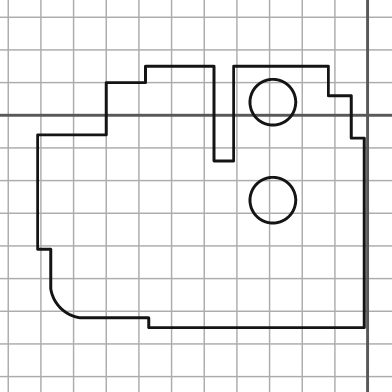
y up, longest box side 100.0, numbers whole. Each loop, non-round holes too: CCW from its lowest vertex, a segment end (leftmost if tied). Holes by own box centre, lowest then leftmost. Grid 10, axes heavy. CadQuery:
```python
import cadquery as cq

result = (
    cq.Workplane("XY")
    .moveTo(-67.0, -65.0)
    .lineTo(-1.0, -65.0)
    .lineTo(-1.0, -7.0)
    .lineTo(-5.0, -7.0)
    .lineTo(-5.0, 6.0)
    .lineTo(-12.0, 6.0)
    .lineTo(-12.0, 15.0)
    .lineTo(-41.0, 15.0)
    .lineTo(-41.0, -14.0)
    .lineTo(-47.0, -14.0)
    .lineTo(-47.0, 15.0)
    .lineTo(-68.0, 15.0)
    .lineTo(-68.0, 10.0)
    .lineTo(-80.0, 10.0)
    .lineTo(-80.0, -6.0)
    .lineTo(-101.0, -6.0)
    .lineTo(-101.0, -41.0)
    .lineTo(-97.0, -41.0)
    .lineTo(-97.0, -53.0)
    .threePointArc((-94.0, -59.0), (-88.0, -62.0))
    .lineTo(-67.0, -62.0)
    .close()
    .moveTo(-29.0, -26.0)
    .circle(7.0)
    .moveTo(-29.0, 4.0)
    .circle(7.0)
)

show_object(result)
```